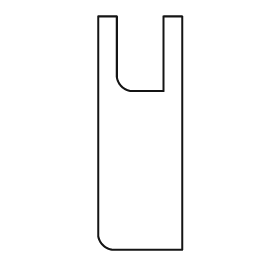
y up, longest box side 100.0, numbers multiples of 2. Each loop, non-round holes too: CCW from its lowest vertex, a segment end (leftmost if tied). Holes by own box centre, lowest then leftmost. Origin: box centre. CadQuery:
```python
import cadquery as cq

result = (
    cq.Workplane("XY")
    .moveTo(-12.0, -50.0)
    .lineTo(18.0, -50.0)
    .lineTo(18.0, 50.0)
    .lineTo(10.0, 50.0)
    .lineTo(10.0, 18.0)
    .lineTo(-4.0, 18.0)
    .threePointArc((-8.0, 20.0), (-10.0, 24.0))
    .lineTo(-10.0, 50.0)
    .lineTo(-18.0, 50.0)
    .lineTo(-18.0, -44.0)
    .threePointArc((-16.0, -48.0), (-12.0, -50.0))
    .close()
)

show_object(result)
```